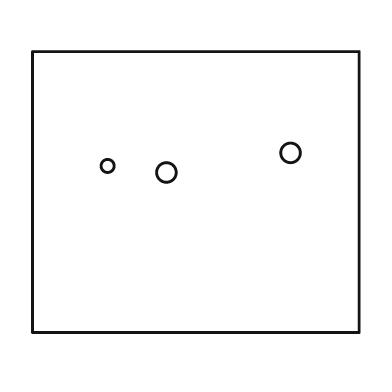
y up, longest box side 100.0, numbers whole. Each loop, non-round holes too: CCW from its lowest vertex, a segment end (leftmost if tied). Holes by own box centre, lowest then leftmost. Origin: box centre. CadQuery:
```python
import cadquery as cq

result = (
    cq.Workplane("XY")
    .moveTo(-50.0, -43.0)
    .lineTo(50.0, -43.0)
    .lineTo(50.0, 43.0)
    .lineTo(-50.0, 43.0)
    .close()
    .moveTo(-9.0, 6.0)
    .circle(3.0)
    .moveTo(-27.0, 8.0)
    .circle(2.0)
    .moveTo(29.0, 12.0)
    .circle(3.0)
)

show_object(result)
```